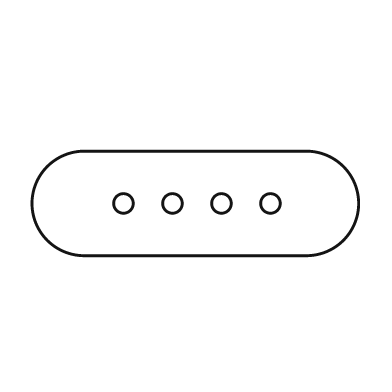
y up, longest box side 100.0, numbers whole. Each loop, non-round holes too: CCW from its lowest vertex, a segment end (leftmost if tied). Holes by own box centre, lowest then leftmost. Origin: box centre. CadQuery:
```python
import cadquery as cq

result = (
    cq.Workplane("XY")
    .moveTo(-34.0, -16.0)
    .lineTo(34.0, -16.0)
    .threePointArc((50.0, 0.0), (34.0, 16.0))
    .lineTo(-34.0, 16.0)
    .threePointArc((-50.0, 0.0), (-34.0, -16.0))
    .close()
    .moveTo(-22.0, 0.0)
    .circle(3.0)
    .moveTo(-7.0, 0.0)
    .circle(3.0)
    .moveTo(8.0, 0.0)
    .circle(3.0)
    .moveTo(23.0, 0.0)
    .circle(3.0)
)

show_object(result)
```